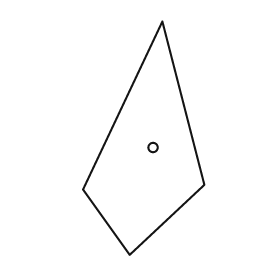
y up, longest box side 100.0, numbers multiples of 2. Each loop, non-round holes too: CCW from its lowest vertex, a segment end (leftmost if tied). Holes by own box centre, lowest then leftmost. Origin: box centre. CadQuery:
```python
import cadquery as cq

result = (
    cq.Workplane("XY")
    .moveTo(-6.0, -50.0)
    .lineTo(26.0, -20.0)
    .lineTo(8.0, 50.0)
    .lineTo(-26.0, -22.0)
    .close()
    .moveTo(4.0, -4.0)
    .circle(2.0)
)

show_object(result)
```